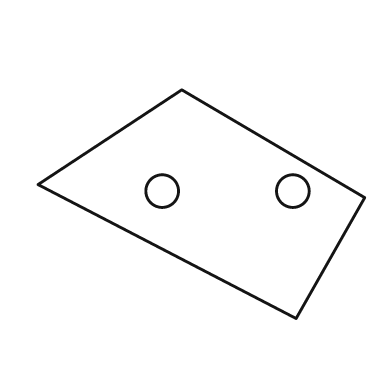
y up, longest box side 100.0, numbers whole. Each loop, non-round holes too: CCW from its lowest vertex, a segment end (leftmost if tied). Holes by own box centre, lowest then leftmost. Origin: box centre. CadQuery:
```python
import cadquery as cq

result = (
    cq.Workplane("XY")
    .moveTo(29.0, -35.0)
    .lineTo(50.0, 2.0)
    .lineTo(-6.0, 35.0)
    .lineTo(-50.0, 6.0)
    .close()
    .moveTo(-12.0, 4.0)
    .circle(5.0)
    .moveTo(28.0, 4.0)
    .circle(5.0)
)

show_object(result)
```